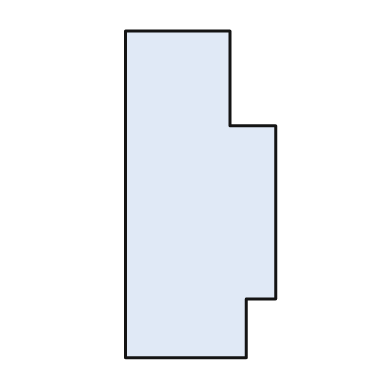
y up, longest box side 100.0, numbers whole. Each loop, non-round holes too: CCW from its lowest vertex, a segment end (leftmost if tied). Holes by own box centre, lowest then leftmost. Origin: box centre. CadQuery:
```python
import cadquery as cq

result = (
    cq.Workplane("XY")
    .moveTo(-23.0, -50.0)
    .lineTo(14.0, -50.0)
    .lineTo(14.0, -32.0)
    .lineTo(23.0, -32.0)
    .lineTo(23.0, 21.0)
    .lineTo(9.0, 21.0)
    .lineTo(9.0, 50.0)
    .lineTo(-23.0, 50.0)
    .close()
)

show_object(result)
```